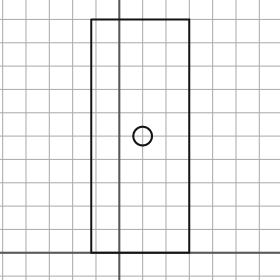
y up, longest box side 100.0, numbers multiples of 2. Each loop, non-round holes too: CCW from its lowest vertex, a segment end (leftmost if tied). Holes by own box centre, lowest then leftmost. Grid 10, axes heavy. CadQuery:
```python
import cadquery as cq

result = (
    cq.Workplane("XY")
    .moveTo(-12.0, 0.0)
    .lineTo(30.0, 0.0)
    .lineTo(30.0, 100.0)
    .lineTo(-12.0, 100.0)
    .close()
    .moveTo(10.0, 50.0)
    .circle(4.0)
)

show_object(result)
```